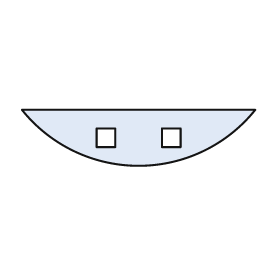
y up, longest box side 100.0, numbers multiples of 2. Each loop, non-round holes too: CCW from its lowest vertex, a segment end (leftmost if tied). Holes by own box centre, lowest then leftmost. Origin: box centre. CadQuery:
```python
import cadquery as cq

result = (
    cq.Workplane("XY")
    .moveTo(-50.0, 12.0)
    .threePointArc((0.0, -12.0), (50.0, 12.0))
    .close()
    .moveTo(-18.0, -4.0)
    .lineTo(-10.0, -4.0)
    .lineTo(-10.0, 4.0)
    .lineTo(-18.0, 4.0)
    .close()
    .moveTo(10.0, -4.0)
    .lineTo(18.0, -4.0)
    .lineTo(18.0, 4.0)
    .lineTo(10.0, 4.0)
    .close()
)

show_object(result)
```